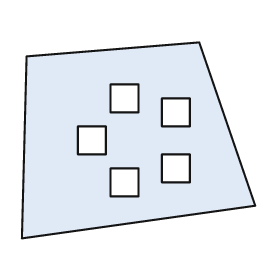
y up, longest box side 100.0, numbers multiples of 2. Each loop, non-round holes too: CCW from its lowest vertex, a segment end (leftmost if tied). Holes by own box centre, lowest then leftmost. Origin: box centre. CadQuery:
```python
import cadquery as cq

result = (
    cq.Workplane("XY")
    .moveTo(-50.0, -42.0)
    .lineTo(50.0, -28.0)
    .lineTo(26.0, 42.0)
    .lineTo(-48.0, 36.0)
    .close()
    .moveTo(-12.0, -24.0)
    .lineTo(0.0, -24.0)
    .lineTo(0.0, -12.0)
    .lineTo(-12.0, -12.0)
    .close()
    .moveTo(10.0, -18.0)
    .lineTo(22.0, -18.0)
    .lineTo(22.0, -6.0)
    .lineTo(10.0, -6.0)
    .close()
    .moveTo(-26.0, -6.0)
    .lineTo(-14.0, -6.0)
    .lineTo(-14.0, 6.0)
    .lineTo(-26.0, 6.0)
    .close()
    .moveTo(10.0, 6.0)
    .lineTo(22.0, 6.0)
    .lineTo(22.0, 18.0)
    .lineTo(10.0, 18.0)
    .close()
    .moveTo(-12.0, 12.0)
    .lineTo(0.0, 12.0)
    .lineTo(0.0, 24.0)
    .lineTo(-12.0, 24.0)
    .close()
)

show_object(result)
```